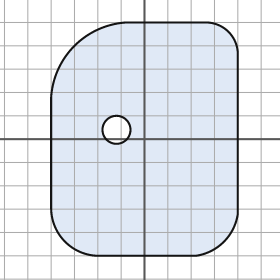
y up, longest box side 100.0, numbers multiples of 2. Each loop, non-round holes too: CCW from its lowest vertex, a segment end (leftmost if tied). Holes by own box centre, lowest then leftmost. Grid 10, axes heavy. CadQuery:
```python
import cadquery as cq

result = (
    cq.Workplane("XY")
    .moveTo(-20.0, -50.0)
    .lineTo(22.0, -50.0)
    .threePointArc((34.0, -44.0), (40.0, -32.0))
    .lineTo(40.0, 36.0)
    .threePointArc((36.0, 46.0), (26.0, 50.0))
    .lineTo(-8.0, 50.0)
    .threePointArc((-30.0, 40.0), (-40.0, 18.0))
    .lineTo(-40.0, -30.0)
    .threePointArc((-34.0, -44.0), (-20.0, -50.0))
    .close()
    .moveTo(-12.0, 4.0)
    .circle(6.0)
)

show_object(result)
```